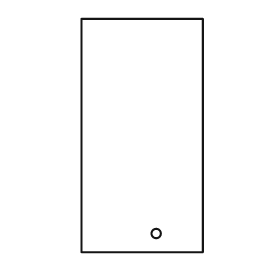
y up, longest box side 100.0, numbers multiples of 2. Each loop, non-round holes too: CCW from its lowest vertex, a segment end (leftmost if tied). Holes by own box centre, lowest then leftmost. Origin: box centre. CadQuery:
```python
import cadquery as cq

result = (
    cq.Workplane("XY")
    .moveTo(-26.0, -50.0)
    .lineTo(26.0, -50.0)
    .lineTo(26.0, 50.0)
    .lineTo(-26.0, 50.0)
    .close()
    .moveTo(6.0, -42.0)
    .circle(2.0)
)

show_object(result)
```